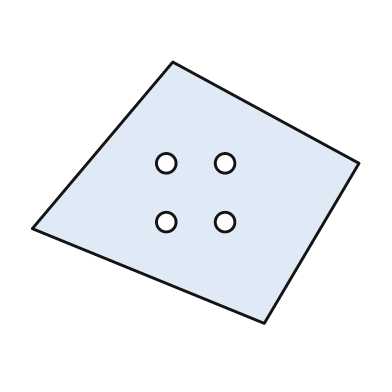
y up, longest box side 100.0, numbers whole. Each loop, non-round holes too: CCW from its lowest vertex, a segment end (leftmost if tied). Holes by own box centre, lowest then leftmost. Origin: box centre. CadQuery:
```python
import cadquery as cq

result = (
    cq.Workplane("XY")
    .moveTo(21.0, -40.0)
    .lineTo(50.0, 9.0)
    .lineTo(-7.0, 40.0)
    .lineTo(-50.0, -11.0)
    .close()
    .moveTo(-9.0, -9.0)
    .circle(3.0)
    .moveTo(9.0, -9.0)
    .circle(3.0)
    .moveTo(-9.0, 9.0)
    .circle(3.0)
    .moveTo(9.0, 9.0)
    .circle(3.0)
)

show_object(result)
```